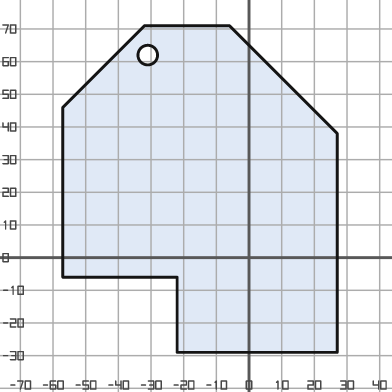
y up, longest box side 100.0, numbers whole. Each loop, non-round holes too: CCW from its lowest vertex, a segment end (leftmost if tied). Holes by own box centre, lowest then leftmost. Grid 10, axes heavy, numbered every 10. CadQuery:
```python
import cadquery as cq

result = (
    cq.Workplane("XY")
    .moveTo(-22.0, -29.0)
    .lineTo(27.0, -29.0)
    .lineTo(27.0, 38.0)
    .lineTo(-6.0, 71.0)
    .lineTo(-32.0, 71.0)
    .lineTo(-57.0, 46.0)
    .lineTo(-57.0, -6.0)
    .lineTo(-22.0, -6.0)
    .close()
    .moveTo(-31.0, 62.0)
    .circle(3.0)
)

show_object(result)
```